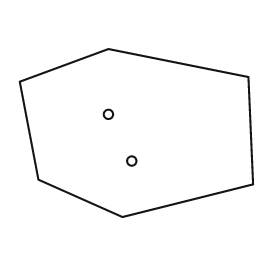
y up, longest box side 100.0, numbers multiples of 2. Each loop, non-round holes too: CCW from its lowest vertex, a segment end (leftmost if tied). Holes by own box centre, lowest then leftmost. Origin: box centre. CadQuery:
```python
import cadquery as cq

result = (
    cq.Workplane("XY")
    .moveTo(-6.0, -36.0)
    .lineTo(50.0, -22.0)
    .lineTo(48.0, 24.0)
    .lineTo(-12.0, 36.0)
    .lineTo(-50.0, 22.0)
    .lineTo(-42.0, -20.0)
    .close()
    .moveTo(-2.0, -12.0)
    .circle(2.0)
    .moveTo(-12.0, 8.0)
    .circle(2.0)
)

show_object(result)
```